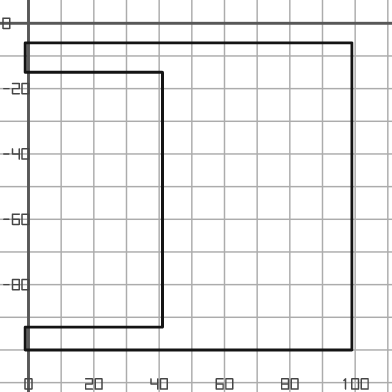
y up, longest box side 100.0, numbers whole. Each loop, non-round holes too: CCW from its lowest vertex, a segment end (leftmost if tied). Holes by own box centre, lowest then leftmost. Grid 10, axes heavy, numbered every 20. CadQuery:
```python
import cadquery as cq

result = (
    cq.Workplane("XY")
    .moveTo(-1.0, -100.0)
    .lineTo(99.0, -100.0)
    .lineTo(99.0, -6.0)
    .lineTo(-1.0, -6.0)
    .lineTo(-1.0, -15.0)
    .lineTo(41.0, -15.0)
    .lineTo(41.0, -93.0)
    .lineTo(-1.0, -93.0)
    .close()
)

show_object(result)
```